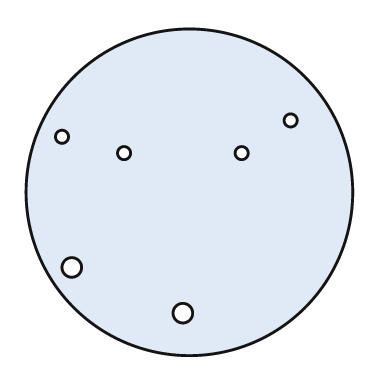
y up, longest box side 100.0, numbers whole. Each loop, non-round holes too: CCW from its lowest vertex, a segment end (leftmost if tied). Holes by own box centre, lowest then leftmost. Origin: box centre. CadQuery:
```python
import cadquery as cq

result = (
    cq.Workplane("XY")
    .moveTo(0.0, 0.0)
    .circle(50.0)
    .moveTo(-2.0, -37.0)
    .circle(3.0)
    .moveTo(-36.0, -23.0)
    .circle(3.0)
    .moveTo(-20.0, 12.0)
    .circle(2.0)
    .moveTo(16.0, 12.0)
    .circle(2.0)
    .moveTo(-39.0, 17.0)
    .circle(2.0)
    .moveTo(31.0, 22.0)
    .circle(2.0)
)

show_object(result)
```